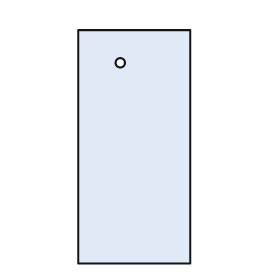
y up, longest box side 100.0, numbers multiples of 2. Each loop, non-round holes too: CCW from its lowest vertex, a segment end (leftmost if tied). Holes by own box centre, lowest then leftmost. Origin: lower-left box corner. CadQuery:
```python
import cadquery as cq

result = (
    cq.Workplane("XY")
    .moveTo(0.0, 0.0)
    .lineTo(48.0, 0.0)
    .lineTo(48.0, 100.0)
    .lineTo(0.0, 100.0)
    .close()
    .moveTo(18.0, 86.0)
    .circle(2.0)
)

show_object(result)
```